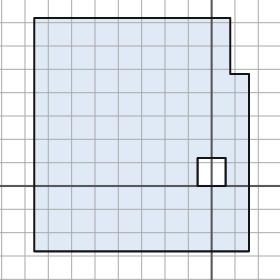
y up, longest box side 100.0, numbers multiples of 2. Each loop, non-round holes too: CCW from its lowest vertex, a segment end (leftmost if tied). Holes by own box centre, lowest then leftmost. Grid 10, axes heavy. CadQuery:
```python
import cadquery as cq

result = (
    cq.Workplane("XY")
    .moveTo(-76.0, -28.0)
    .lineTo(16.0, -28.0)
    .lineTo(16.0, 48.0)
    .lineTo(8.0, 48.0)
    .lineTo(8.0, 72.0)
    .lineTo(-76.0, 72.0)
    .close()
    .moveTo(-6.0, 0.0)
    .lineTo(6.0, 0.0)
    .lineTo(6.0, 12.0)
    .lineTo(-6.0, 12.0)
    .close()
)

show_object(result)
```